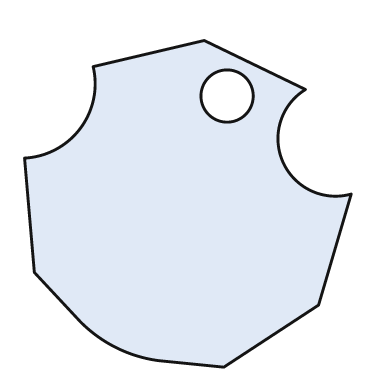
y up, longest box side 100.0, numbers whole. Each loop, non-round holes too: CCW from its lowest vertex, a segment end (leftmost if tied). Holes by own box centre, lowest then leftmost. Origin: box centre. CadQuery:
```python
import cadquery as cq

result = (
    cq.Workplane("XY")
    .moveTo(11.0, -50.0)
    .lineTo(40.0, -31.0)
    .lineTo(50.0, 3.0)
    .threePointArc((29.0, 13.0), (36.0, 35.0))
    .lineTo(5.0, 50.0)
    .lineTo(-29.0, 42.0)
    .threePointArc((-33.0, 23.0), (-50.0, 14.0))
    .lineTo(-47.0, -21.0)
    .lineTo(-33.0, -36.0)
    .threePointArc((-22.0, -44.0), (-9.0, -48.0))
    .close()
    .moveTo(12.0, 33.0)
    .circle(8.0)
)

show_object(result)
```